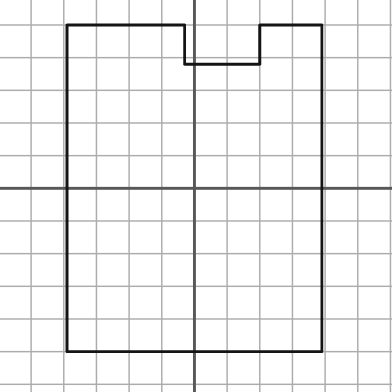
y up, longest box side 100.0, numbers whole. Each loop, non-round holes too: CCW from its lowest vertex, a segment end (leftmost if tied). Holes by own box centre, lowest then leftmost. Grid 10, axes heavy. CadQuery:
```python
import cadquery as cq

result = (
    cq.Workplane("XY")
    .moveTo(-39.0, -50.0)
    .lineTo(39.0, -50.0)
    .lineTo(39.0, 50.0)
    .lineTo(20.0, 50.0)
    .lineTo(20.0, 38.0)
    .lineTo(-3.0, 38.0)
    .lineTo(-3.0, 50.0)
    .lineTo(-39.0, 50.0)
    .close()
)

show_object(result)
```